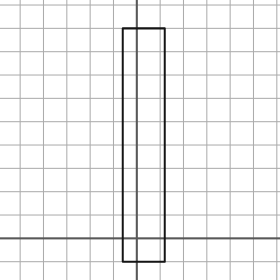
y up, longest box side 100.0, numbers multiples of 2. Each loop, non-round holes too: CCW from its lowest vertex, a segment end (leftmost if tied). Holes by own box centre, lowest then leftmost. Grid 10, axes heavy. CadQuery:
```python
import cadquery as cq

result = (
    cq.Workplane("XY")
    .moveTo(-6.0, -10.0)
    .lineTo(12.0, -10.0)
    .lineTo(12.0, 90.0)
    .lineTo(-6.0, 90.0)
    .close()
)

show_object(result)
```